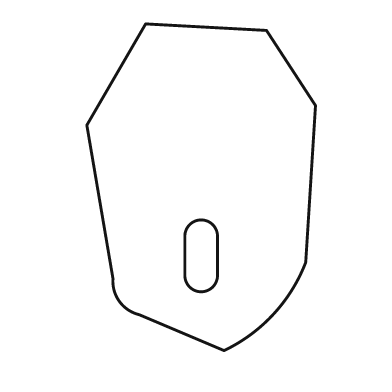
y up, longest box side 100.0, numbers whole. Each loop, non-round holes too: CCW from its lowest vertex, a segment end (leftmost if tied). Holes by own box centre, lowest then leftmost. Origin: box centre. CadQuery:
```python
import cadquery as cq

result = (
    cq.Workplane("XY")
    .moveTo(7.0, -50.0)
    .threePointArc((22.0, -39.0), (32.0, -23.0))
    .lineTo(35.0, 25.0)
    .lineTo(20.0, 48.0)
    .lineTo(-17.0, 50.0)
    .lineTo(-35.0, 19.0)
    .lineTo(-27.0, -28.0)
    .threePointArc((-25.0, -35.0), (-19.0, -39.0))
    .close()
    .moveTo(-5.0, -27.0)
    .threePointArc((0.0, -32.0), (5.0, -27.0))
    .lineTo(5.0, -15.0)
    .threePointArc((0.0, -10.0), (-5.0, -15.0))
    .close()
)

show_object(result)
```